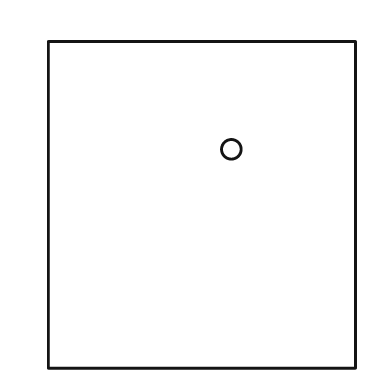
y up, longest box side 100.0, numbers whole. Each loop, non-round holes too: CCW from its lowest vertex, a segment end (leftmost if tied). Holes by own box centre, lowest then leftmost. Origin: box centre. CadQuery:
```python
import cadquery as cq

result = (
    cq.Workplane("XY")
    .moveTo(-47.0, -50.0)
    .lineTo(47.0, -50.0)
    .lineTo(47.0, 50.0)
    .lineTo(-47.0, 50.0)
    .close()
    .moveTo(9.0, 17.0)
    .circle(3.0)
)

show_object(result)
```